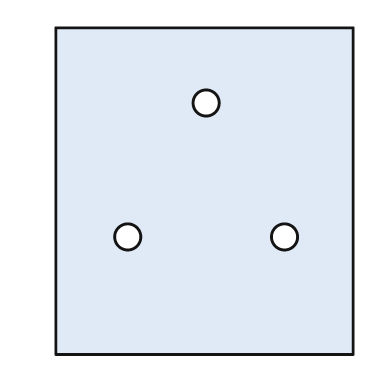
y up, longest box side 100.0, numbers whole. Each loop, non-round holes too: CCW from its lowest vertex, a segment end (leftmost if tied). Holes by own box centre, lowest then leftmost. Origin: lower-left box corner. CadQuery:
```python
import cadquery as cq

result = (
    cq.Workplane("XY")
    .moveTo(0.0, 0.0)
    .lineTo(91.0, 0.0)
    .lineTo(91.0, 100.0)
    .lineTo(0.0, 100.0)
    .close()
    .moveTo(22.0, 36.0)
    .circle(4.0)
    .moveTo(70.0, 36.0)
    .circle(4.0)
    .moveTo(46.0, 77.0)
    .circle(4.0)
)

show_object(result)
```